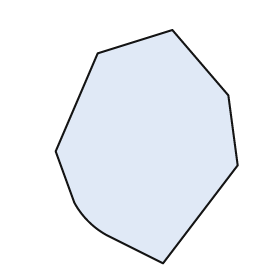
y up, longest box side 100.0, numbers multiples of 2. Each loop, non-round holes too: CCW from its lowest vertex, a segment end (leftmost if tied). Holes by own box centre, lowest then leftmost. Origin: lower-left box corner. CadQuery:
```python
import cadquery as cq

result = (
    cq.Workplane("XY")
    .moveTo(46.0, 0.0)
    .lineTo(78.0, 42.0)
    .lineTo(74.0, 72.0)
    .lineTo(50.0, 100.0)
    .lineTo(18.0, 90.0)
    .lineTo(0.0, 48.0)
    .lineTo(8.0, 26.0)
    .threePointArc((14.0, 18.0), (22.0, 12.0))
    .close()
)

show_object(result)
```